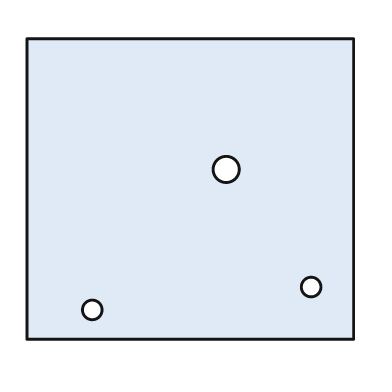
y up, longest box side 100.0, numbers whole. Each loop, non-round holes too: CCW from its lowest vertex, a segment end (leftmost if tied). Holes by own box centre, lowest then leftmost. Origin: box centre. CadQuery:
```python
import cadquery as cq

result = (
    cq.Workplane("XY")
    .moveTo(-50.0, -46.0)
    .lineTo(50.0, -46.0)
    .lineTo(50.0, 46.0)
    .lineTo(-50.0, 46.0)
    .close()
    .moveTo(-30.0, -37.0)
    .circle(3.0)
    .moveTo(37.0, -30.0)
    .circle(3.0)
    .moveTo(11.0, 6.0)
    .circle(4.0)
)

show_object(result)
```